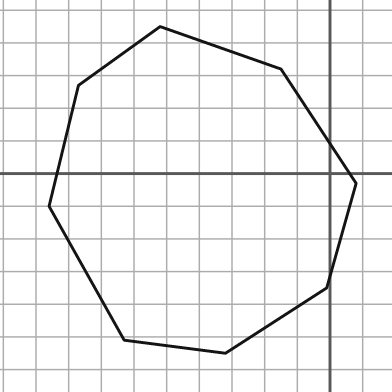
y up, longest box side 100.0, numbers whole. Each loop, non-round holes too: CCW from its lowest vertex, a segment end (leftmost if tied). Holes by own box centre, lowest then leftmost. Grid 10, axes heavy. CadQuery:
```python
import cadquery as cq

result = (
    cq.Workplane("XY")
    .moveTo(-32.0, -55.0)
    .lineTo(-1.0, -35.0)
    .lineTo(8.0, -3.0)
    .lineTo(-15.0, 32.0)
    .lineTo(-52.0, 45.0)
    .lineTo(-77.0, 27.0)
    .lineTo(-86.0, -10.0)
    .lineTo(-63.0, -51.0)
    .close()
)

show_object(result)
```